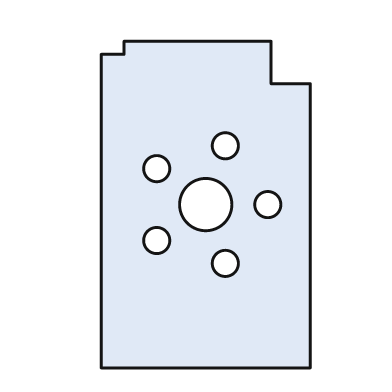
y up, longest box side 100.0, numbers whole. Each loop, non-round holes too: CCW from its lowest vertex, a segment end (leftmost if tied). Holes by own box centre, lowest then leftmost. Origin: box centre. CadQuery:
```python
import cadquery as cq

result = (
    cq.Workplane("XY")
    .moveTo(-32.0, -50.0)
    .lineTo(32.0, -50.0)
    .lineTo(32.0, 37.0)
    .lineTo(20.0, 37.0)
    .lineTo(20.0, 50.0)
    .lineTo(-25.0, 50.0)
    .lineTo(-25.0, 46.0)
    .lineTo(-32.0, 46.0)
    .close()
    .moveTo(6.0, -18.0)
    .circle(4.0)
    .moveTo(-15.0, -11.0)
    .circle(4.0)
    .moveTo(0.0, 0.0)
    .circle(8.0)
    .moveTo(19.0, 0.0)
    .circle(4.0)
    .moveTo(-15.0, 11.0)
    .circle(4.0)
    .moveTo(6.0, 18.0)
    .circle(4.0)
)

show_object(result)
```